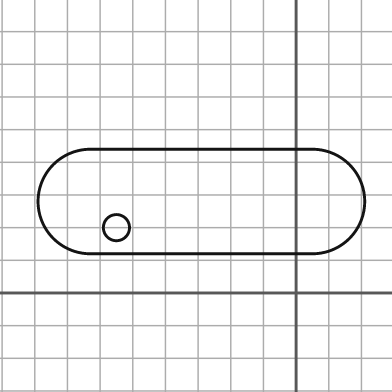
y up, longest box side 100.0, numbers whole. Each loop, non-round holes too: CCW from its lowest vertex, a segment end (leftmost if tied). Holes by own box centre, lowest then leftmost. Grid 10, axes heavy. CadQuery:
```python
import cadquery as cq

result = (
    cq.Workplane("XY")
    .moveTo(-63.0, 12.0)
    .lineTo(5.0, 12.0)
    .threePointArc((21.0, 28.0), (5.0, 44.0))
    .lineTo(-63.0, 44.0)
    .threePointArc((-79.0, 28.0), (-63.0, 12.0))
    .close()
    .moveTo(-55.0, 20.0)
    .circle(4.0)
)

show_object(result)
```